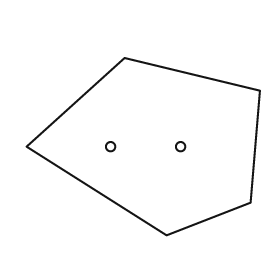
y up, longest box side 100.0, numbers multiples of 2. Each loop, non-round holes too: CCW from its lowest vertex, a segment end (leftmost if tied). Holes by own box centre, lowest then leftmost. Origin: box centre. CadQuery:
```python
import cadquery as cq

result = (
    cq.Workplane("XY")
    .moveTo(10.0, -38.0)
    .lineTo(46.0, -24.0)
    .lineTo(50.0, 24.0)
    .lineTo(-8.0, 38.0)
    .lineTo(-50.0, 0.0)
    .close()
    .moveTo(-14.0, 0.0)
    .circle(2.0)
    .moveTo(16.0, 0.0)
    .circle(2.0)
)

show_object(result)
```